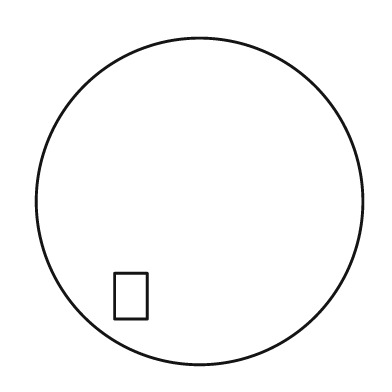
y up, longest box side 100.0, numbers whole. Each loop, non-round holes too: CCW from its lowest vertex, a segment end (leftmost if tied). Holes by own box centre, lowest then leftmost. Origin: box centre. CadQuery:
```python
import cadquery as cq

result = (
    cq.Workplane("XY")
    .moveTo(0.0, 0.0)
    .circle(50.0)
    .moveTo(-26.0, -36.0)
    .lineTo(-16.0, -36.0)
    .lineTo(-16.0, -22.0)
    .lineTo(-26.0, -22.0)
    .close()
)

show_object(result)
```